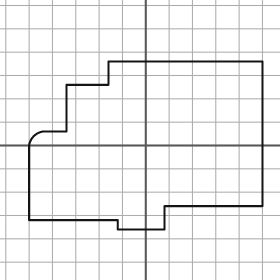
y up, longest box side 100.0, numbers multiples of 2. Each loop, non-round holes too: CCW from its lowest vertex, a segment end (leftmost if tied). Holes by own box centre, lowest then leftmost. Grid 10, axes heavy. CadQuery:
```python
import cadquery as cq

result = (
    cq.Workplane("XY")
    .moveTo(-12.0, -36.0)
    .lineTo(8.0, -36.0)
    .lineTo(8.0, -26.0)
    .lineTo(50.0, -26.0)
    .lineTo(50.0, 36.0)
    .lineTo(-16.0, 36.0)
    .lineTo(-16.0, 26.0)
    .lineTo(-34.0, 26.0)
    .lineTo(-34.0, 6.0)
    .lineTo(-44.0, 6.0)
    .threePointArc((-48.0, 4.0), (-50.0, 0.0))
    .lineTo(-50.0, -32.0)
    .lineTo(-12.0, -32.0)
    .close()
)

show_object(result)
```